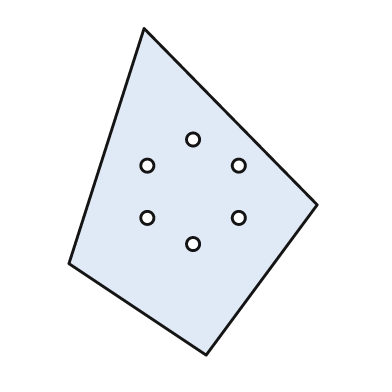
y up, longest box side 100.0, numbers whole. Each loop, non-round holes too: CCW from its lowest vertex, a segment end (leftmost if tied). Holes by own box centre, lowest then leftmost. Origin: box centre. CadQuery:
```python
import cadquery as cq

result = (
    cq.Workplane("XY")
    .moveTo(4.0, -50.0)
    .lineTo(38.0, -4.0)
    .lineTo(-15.0, 50.0)
    .lineTo(-38.0, -22.0)
    .close()
    .moveTo(0.0, -16.0)
    .circle(2.0)
    .moveTo(-14.0, -8.0)
    .circle(2.0)
    .moveTo(14.0, -8.0)
    .circle(2.0)
    .moveTo(-14.0, 8.0)
    .circle(2.0)
    .moveTo(14.0, 8.0)
    .circle(2.0)
    .moveTo(0.0, 16.0)
    .circle(2.0)
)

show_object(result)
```